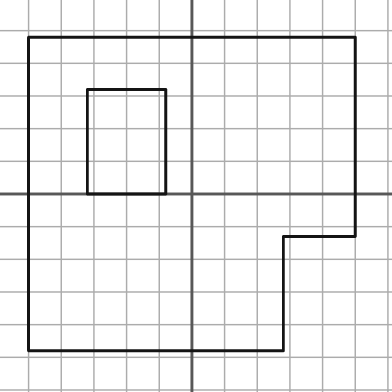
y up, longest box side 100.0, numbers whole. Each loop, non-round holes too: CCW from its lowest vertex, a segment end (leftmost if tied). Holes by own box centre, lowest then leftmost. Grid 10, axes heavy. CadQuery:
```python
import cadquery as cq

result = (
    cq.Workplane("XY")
    .moveTo(-50.0, -48.0)
    .lineTo(28.0, -48.0)
    .lineTo(28.0, -13.0)
    .lineTo(50.0, -13.0)
    .lineTo(50.0, 48.0)
    .lineTo(-50.0, 48.0)
    .close()
    .moveTo(-32.0, 0.0)
    .lineTo(-8.0, 0.0)
    .lineTo(-8.0, 32.0)
    .lineTo(-32.0, 32.0)
    .close()
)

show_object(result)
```